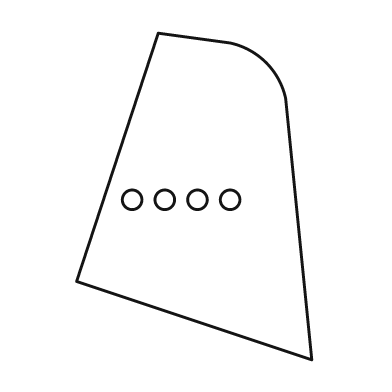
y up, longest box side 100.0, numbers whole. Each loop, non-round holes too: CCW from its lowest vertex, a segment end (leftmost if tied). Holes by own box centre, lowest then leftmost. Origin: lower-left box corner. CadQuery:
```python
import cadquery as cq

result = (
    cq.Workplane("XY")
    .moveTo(72.0, 0.0)
    .lineTo(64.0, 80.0)
    .threePointArc((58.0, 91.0), (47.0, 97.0))
    .lineTo(25.0, 100.0)
    .lineTo(0.0, 24.0)
    .close()
    .moveTo(17.0, 49.0)
    .circle(3.0)
    .moveTo(27.0, 49.0)
    .circle(3.0)
    .moveTo(37.0, 49.0)
    .circle(3.0)
    .moveTo(47.0, 49.0)
    .circle(3.0)
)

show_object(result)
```